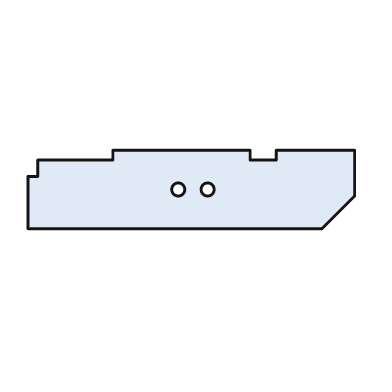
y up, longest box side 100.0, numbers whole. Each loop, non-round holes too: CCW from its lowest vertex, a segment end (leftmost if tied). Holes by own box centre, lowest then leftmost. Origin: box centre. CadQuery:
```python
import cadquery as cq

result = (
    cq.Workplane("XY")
    .moveTo(-50.0, -12.0)
    .lineTo(40.0, -12.0)
    .lineTo(50.0, -2.0)
    .lineTo(50.0, 12.0)
    .lineTo(26.0, 12.0)
    .lineTo(26.0, 9.0)
    .lineTo(18.0, 9.0)
    .lineTo(18.0, 12.0)
    .lineTo(-24.0, 12.0)
    .lineTo(-24.0, 9.0)
    .lineTo(-47.0, 9.0)
    .lineTo(-47.0, 4.0)
    .lineTo(-50.0, 4.0)
    .close()
    .moveTo(-4.0, 0.0)
    .circle(2.0)
    .moveTo(5.0, 0.0)
    .circle(2.0)
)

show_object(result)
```